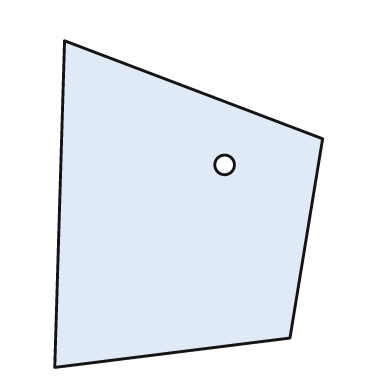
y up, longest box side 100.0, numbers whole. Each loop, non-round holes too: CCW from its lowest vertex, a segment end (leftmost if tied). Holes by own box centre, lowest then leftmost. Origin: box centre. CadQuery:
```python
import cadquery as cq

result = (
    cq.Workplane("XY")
    .moveTo(-41.0, -50.0)
    .lineTo(31.0, -41.0)
    .lineTo(41.0, 20.0)
    .lineTo(-38.0, 50.0)
    .close()
    .moveTo(11.0, 12.0)
    .circle(3.0)
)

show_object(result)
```